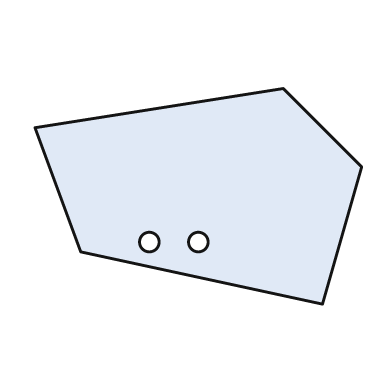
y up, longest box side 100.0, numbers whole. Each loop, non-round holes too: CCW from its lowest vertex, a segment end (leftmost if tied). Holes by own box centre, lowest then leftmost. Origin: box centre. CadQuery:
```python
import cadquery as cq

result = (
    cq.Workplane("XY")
    .moveTo(38.0, -33.0)
    .lineTo(50.0, 9.0)
    .lineTo(26.0, 33.0)
    .lineTo(-50.0, 21.0)
    .lineTo(-36.0, -17.0)
    .close()
    .moveTo(-15.0, -14.0)
    .circle(3.0)
    .moveTo(0.0, -14.0)
    .circle(3.0)
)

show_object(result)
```